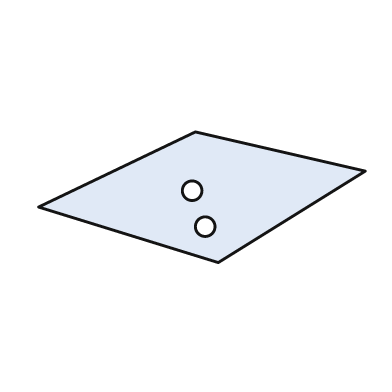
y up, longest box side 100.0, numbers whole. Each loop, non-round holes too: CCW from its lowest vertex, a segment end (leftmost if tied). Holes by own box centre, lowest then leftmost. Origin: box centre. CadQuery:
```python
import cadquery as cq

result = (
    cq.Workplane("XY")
    .moveTo(5.0, -20.0)
    .lineTo(50.0, 8.0)
    .lineTo(-2.0, 20.0)
    .lineTo(-50.0, -3.0)
    .close()
    .moveTo(1.0, -9.0)
    .circle(3.0)
    .moveTo(-3.0, 2.0)
    .circle(3.0)
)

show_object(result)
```